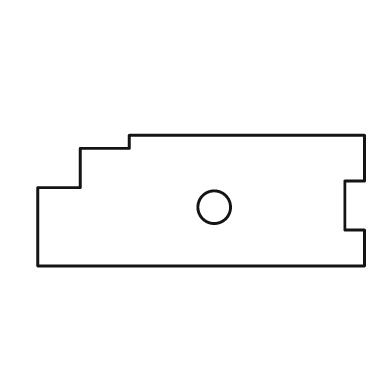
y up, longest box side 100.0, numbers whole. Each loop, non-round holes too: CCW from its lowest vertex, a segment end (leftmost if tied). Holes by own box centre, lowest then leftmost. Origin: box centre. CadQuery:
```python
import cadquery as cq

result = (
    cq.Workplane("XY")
    .moveTo(-50.0, -20.0)
    .lineTo(50.0, -20.0)
    .lineTo(50.0, -9.0)
    .lineTo(44.0, -9.0)
    .lineTo(44.0, 6.0)
    .lineTo(50.0, 6.0)
    .lineTo(50.0, 20.0)
    .lineTo(-22.0, 20.0)
    .lineTo(-22.0, 16.0)
    .lineTo(-37.0, 16.0)
    .lineTo(-37.0, 4.0)
    .lineTo(-50.0, 4.0)
    .close()
    .moveTo(4.0, -2.0)
    .circle(5.0)
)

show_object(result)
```